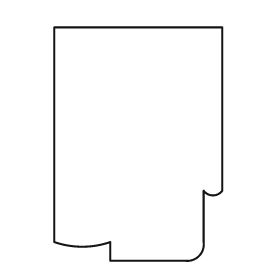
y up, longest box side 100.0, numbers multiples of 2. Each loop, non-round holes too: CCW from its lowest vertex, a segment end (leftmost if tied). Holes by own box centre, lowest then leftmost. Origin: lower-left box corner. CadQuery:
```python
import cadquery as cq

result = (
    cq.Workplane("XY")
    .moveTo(24.0, 0.0)
    .lineTo(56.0, 0.0)
    .threePointArc((62.0, 2.0), (64.0, 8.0))
    .lineTo(64.0, 30.0)
    .threePointArc((68.0, 28.0), (72.0, 30.0))
    .lineTo(72.0, 100.0)
    .lineTo(0.0, 100.0)
    .lineTo(0.0, 8.0)
    .threePointArc((12.0, 6.0), (24.0, 8.0))
    .close()
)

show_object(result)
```